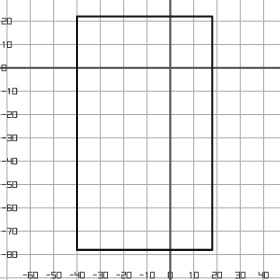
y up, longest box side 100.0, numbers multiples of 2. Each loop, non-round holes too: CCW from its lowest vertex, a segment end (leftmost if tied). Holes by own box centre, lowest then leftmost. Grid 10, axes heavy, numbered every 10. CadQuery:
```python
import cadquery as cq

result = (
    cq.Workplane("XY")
    .moveTo(-40.0, -78.0)
    .lineTo(18.0, -78.0)
    .lineTo(18.0, 22.0)
    .lineTo(-40.0, 22.0)
    .close()
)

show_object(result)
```